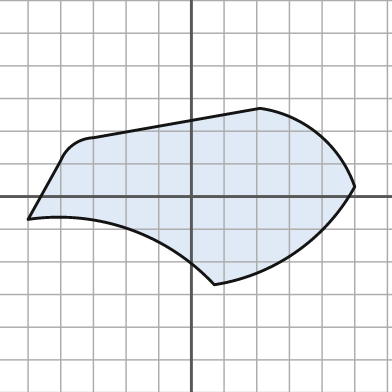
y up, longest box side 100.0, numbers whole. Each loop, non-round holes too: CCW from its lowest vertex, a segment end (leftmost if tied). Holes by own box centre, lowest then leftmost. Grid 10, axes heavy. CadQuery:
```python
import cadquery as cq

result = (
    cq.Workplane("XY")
    .moveTo(7.0, -27.0)
    .threePointArc((32.0, -17.0), (50.0, 3.0))
    .threePointArc((39.0, 19.0), (21.0, 27.0))
    .lineTo(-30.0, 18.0)
    .threePointArc((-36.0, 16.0), (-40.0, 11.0))
    .lineTo(-50.0, -7.0)
    .threePointArc((-19.0, -10.0), (7.0, -27.0))
    .close()
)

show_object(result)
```